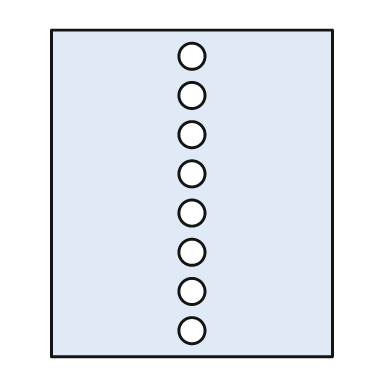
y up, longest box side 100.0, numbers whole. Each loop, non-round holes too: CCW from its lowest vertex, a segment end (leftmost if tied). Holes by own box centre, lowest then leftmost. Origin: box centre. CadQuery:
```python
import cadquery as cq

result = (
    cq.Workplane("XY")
    .moveTo(-43.0, -50.0)
    .lineTo(43.0, -50.0)
    .lineTo(43.0, 50.0)
    .lineTo(-43.0, 50.0)
    .close()
    .moveTo(0.0, -42.0)
    .circle(4.0)
    .moveTo(0.0, -30.0)
    .circle(4.0)
    .moveTo(0.0, -18.0)
    .circle(4.0)
    .moveTo(0.0, -6.0)
    .circle(4.0)
    .moveTo(0.0, 6.0)
    .circle(4.0)
    .moveTo(0.0, 18.0)
    .circle(4.0)
    .moveTo(0.0, 30.0)
    .circle(4.0)
    .moveTo(0.0, 42.0)
    .circle(4.0)
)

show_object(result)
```